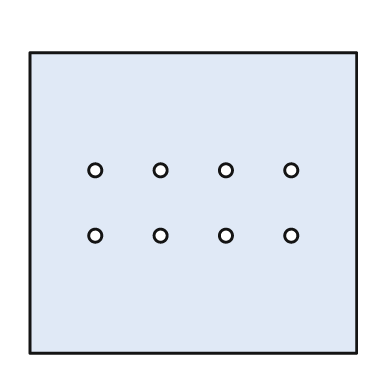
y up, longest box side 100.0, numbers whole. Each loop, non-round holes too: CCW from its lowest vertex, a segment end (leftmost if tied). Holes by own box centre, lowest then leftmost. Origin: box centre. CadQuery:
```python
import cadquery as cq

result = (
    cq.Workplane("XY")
    .moveTo(-50.0, -46.0)
    .lineTo(50.0, -46.0)
    .lineTo(50.0, 46.0)
    .lineTo(-50.0, 46.0)
    .close()
    .moveTo(-30.0, -10.0)
    .circle(2.0)
    .moveTo(-10.0, -10.0)
    .circle(2.0)
    .moveTo(10.0, -10.0)
    .circle(2.0)
    .moveTo(30.0, -10.0)
    .circle(2.0)
    .moveTo(-30.0, 10.0)
    .circle(2.0)
    .moveTo(-10.0, 10.0)
    .circle(2.0)
    .moveTo(10.0, 10.0)
    .circle(2.0)
    .moveTo(30.0, 10.0)
    .circle(2.0)
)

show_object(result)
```